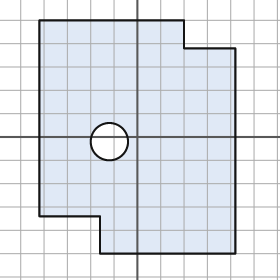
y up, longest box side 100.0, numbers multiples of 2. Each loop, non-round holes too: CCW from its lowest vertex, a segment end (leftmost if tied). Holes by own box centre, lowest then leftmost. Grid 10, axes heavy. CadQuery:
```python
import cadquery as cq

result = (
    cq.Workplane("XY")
    .moveTo(-16.0, -50.0)
    .lineTo(42.0, -50.0)
    .lineTo(42.0, 38.0)
    .lineTo(20.0, 38.0)
    .lineTo(20.0, 50.0)
    .lineTo(-42.0, 50.0)
    .lineTo(-42.0, -34.0)
    .lineTo(-16.0, -34.0)
    .close()
    .moveTo(-12.0, -2.0)
    .circle(8.0)
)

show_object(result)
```